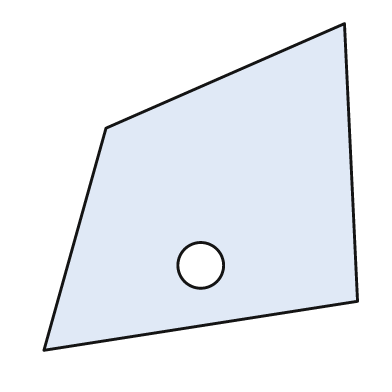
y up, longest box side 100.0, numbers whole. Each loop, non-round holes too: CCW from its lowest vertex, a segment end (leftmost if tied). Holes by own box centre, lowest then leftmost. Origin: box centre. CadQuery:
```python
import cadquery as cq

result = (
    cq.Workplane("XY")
    .moveTo(-48.0, -50.0)
    .lineTo(48.0, -35.0)
    .lineTo(44.0, 50.0)
    .lineTo(-29.0, 18.0)
    .close()
    .moveTo(0.0, -24.0)
    .circle(7.0)
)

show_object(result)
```